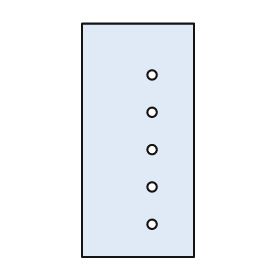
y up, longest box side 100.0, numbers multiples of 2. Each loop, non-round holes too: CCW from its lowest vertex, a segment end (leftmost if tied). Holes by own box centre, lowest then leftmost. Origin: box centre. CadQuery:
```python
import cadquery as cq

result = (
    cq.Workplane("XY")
    .moveTo(-24.0, -50.0)
    .lineTo(24.0, -50.0)
    .lineTo(24.0, 50.0)
    .lineTo(-24.0, 50.0)
    .close()
    .moveTo(6.0, -36.0)
    .circle(2.0)
    .moveTo(6.0, -20.0)
    .circle(2.0)
    .moveTo(6.0, -4.0)
    .circle(2.0)
    .moveTo(6.0, 12.0)
    .circle(2.0)
    .moveTo(6.0, 28.0)
    .circle(2.0)
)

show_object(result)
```